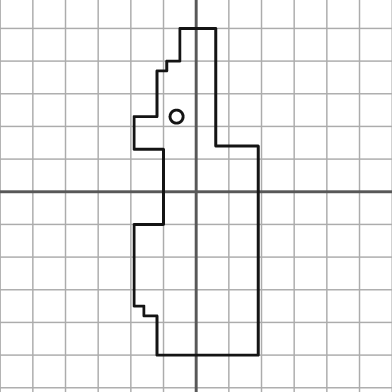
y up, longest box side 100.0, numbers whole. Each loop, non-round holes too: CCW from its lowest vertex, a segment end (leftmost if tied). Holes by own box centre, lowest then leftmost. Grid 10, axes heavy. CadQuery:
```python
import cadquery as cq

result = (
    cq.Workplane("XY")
    .moveTo(-12.0, -50.0)
    .lineTo(19.0, -50.0)
    .lineTo(19.0, 14.0)
    .lineTo(6.0, 14.0)
    .lineTo(6.0, 50.0)
    .lineTo(-5.0, 50.0)
    .lineTo(-5.0, 40.0)
    .lineTo(-9.0, 40.0)
    .lineTo(-9.0, 37.0)
    .lineTo(-12.0, 37.0)
    .lineTo(-12.0, 23.0)
    .lineTo(-19.0, 23.0)
    .lineTo(-19.0, 13.0)
    .lineTo(-10.0, 13.0)
    .lineTo(-10.0, -10.0)
    .lineTo(-19.0, -10.0)
    .lineTo(-19.0, -35.0)
    .lineTo(-16.0, -35.0)
    .lineTo(-16.0, -38.0)
    .lineTo(-12.0, -38.0)
    .close()
    .moveTo(-6.0, 23.0)
    .circle(2.0)
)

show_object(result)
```